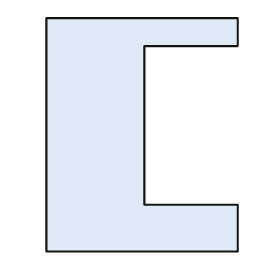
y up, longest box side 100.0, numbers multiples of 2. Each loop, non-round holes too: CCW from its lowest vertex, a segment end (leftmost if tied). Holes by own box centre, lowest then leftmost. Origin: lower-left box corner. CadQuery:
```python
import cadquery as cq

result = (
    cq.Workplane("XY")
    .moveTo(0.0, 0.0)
    .lineTo(82.0, 0.0)
    .lineTo(82.0, 20.0)
    .lineTo(42.0, 20.0)
    .lineTo(42.0, 88.0)
    .lineTo(82.0, 88.0)
    .lineTo(82.0, 100.0)
    .lineTo(0.0, 100.0)
    .close()
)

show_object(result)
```